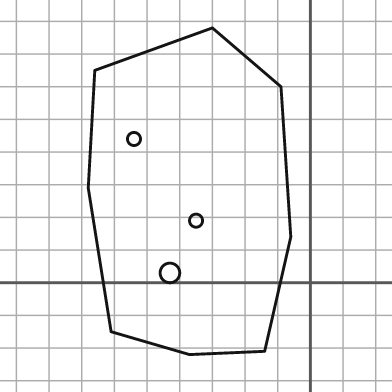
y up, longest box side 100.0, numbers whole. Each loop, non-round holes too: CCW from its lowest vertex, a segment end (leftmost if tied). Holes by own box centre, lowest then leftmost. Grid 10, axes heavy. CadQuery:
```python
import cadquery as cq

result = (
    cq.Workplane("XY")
    .moveTo(-37.0, -22.0)
    .lineTo(-14.0, -21.0)
    .lineTo(-6.0, 14.0)
    .lineTo(-9.0, 60.0)
    .lineTo(-30.0, 78.0)
    .lineTo(-66.0, 65.0)
    .lineTo(-68.0, 29.0)
    .lineTo(-61.0, -15.0)
    .close()
    .moveTo(-43.0, 3.0)
    .circle(3.0)
    .moveTo(-35.0, 19.0)
    .circle(2.0)
    .moveTo(-54.0, 44.0)
    .circle(2.0)
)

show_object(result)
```